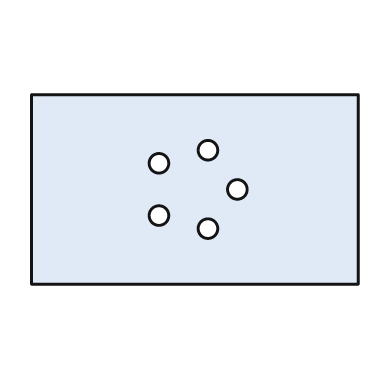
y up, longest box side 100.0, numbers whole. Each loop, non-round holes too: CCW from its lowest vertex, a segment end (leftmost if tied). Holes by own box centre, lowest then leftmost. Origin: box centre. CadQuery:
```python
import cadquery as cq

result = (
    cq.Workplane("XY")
    .moveTo(-50.0, -29.0)
    .lineTo(50.0, -29.0)
    .lineTo(50.0, 29.0)
    .lineTo(-50.0, 29.0)
    .close()
    .moveTo(4.0, -12.0)
    .circle(3.0)
    .moveTo(-11.0, -8.0)
    .circle(3.0)
    .moveTo(13.0, 0.0)
    .circle(3.0)
    .moveTo(-11.0, 8.0)
    .circle(3.0)
    .moveTo(4.0, 12.0)
    .circle(3.0)
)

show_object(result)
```